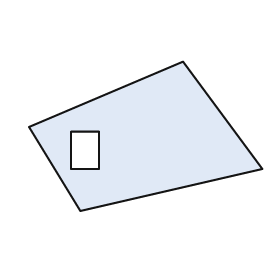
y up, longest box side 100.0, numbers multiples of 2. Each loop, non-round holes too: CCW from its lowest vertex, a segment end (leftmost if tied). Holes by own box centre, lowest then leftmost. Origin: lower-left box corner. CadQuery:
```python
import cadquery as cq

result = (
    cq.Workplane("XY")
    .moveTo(22.0, 0.0)
    .lineTo(100.0, 18.0)
    .lineTo(66.0, 64.0)
    .lineTo(0.0, 36.0)
    .close()
    .moveTo(18.0, 18.0)
    .lineTo(30.0, 18.0)
    .lineTo(30.0, 34.0)
    .lineTo(18.0, 34.0)
    .close()
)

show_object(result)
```